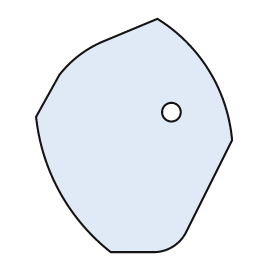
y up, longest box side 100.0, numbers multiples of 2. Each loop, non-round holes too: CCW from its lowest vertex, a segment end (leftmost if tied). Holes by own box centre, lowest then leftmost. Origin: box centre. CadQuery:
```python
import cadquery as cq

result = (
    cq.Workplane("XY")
    .moveTo(-10.0, -50.0)
    .lineTo(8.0, -50.0)
    .threePointArc((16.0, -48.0), (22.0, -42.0))
    .lineTo(42.0, -2.0)
    .threePointArc((32.0, 28.0), (10.0, 50.0))
    .lineTo(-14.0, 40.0)
    .threePointArc((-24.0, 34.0), (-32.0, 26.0))
    .lineTo(-42.0, 8.0)
    .threePointArc((-32.0, -24.0), (-10.0, -50.0))
    .close()
    .moveTo(16.0, 10.0)
    .circle(4.0)
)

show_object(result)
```